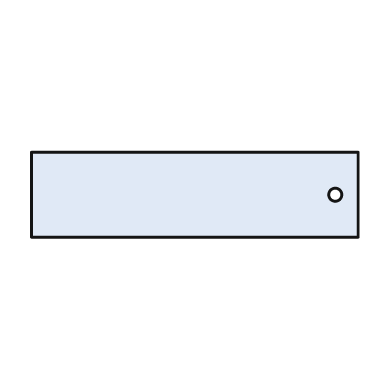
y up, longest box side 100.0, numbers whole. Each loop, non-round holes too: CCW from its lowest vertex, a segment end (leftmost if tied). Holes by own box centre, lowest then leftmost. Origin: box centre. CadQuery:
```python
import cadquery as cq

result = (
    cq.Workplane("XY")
    .moveTo(-50.0, -13.0)
    .lineTo(50.0, -13.0)
    .lineTo(50.0, 13.0)
    .lineTo(-50.0, 13.0)
    .close()
    .moveTo(43.0, 0.0)
    .circle(2.0)
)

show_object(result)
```